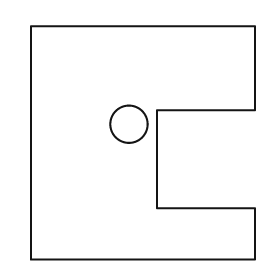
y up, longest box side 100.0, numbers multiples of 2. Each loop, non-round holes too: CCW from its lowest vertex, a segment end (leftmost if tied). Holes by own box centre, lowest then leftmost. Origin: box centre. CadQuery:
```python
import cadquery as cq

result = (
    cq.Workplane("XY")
    .moveTo(-48.0, -50.0)
    .lineTo(48.0, -50.0)
    .lineTo(48.0, -28.0)
    .lineTo(6.0, -28.0)
    .lineTo(6.0, 14.0)
    .lineTo(48.0, 14.0)
    .lineTo(48.0, 50.0)
    .lineTo(-48.0, 50.0)
    .close()
    .moveTo(-6.0, 8.0)
    .circle(8.0)
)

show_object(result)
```